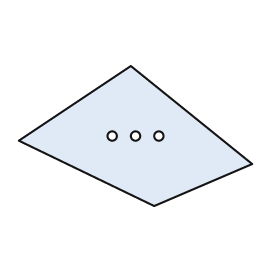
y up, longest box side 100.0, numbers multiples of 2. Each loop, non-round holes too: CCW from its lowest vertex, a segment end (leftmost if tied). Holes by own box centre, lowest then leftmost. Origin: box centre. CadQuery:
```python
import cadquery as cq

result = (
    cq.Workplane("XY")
    .moveTo(8.0, -30.0)
    .lineTo(50.0, -12.0)
    .lineTo(-2.0, 30.0)
    .lineTo(-50.0, -2.0)
    .close()
    .moveTo(-10.0, 0.0)
    .circle(2.0)
    .moveTo(0.0, 0.0)
    .circle(2.0)
    .moveTo(10.0, 0.0)
    .circle(2.0)
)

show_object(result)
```